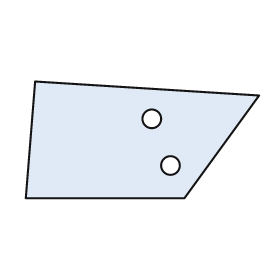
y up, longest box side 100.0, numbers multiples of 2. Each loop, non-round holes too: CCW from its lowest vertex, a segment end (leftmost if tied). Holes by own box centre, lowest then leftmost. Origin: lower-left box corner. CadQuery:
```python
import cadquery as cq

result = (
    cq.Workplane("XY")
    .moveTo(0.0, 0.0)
    .lineTo(68.0, 0.0)
    .lineTo(100.0, 44.0)
    .lineTo(4.0, 50.0)
    .close()
    .moveTo(62.0, 14.0)
    .circle(4.0)
    .moveTo(54.0, 34.0)
    .circle(4.0)
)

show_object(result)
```